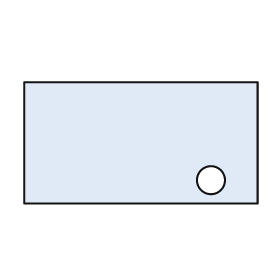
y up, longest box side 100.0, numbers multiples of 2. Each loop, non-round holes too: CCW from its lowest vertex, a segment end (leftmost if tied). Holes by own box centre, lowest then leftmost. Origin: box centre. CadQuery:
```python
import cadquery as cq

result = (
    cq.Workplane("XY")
    .moveTo(-50.0, -26.0)
    .lineTo(50.0, -26.0)
    .lineTo(50.0, 26.0)
    .lineTo(-50.0, 26.0)
    .close()
    .moveTo(30.0, -16.0)
    .circle(6.0)
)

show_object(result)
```